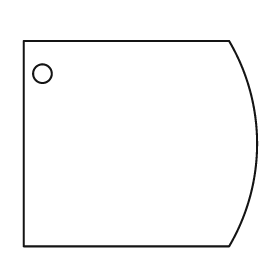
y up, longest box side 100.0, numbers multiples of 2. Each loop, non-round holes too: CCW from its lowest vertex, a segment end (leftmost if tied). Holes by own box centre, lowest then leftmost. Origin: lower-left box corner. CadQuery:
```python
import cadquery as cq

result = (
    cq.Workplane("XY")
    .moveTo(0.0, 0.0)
    .lineTo(88.0, 0.0)
    .threePointArc((100.0, 44.0), (88.0, 88.0))
    .lineTo(0.0, 88.0)
    .close()
    .moveTo(8.0, 74.0)
    .circle(4.0)
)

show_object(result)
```